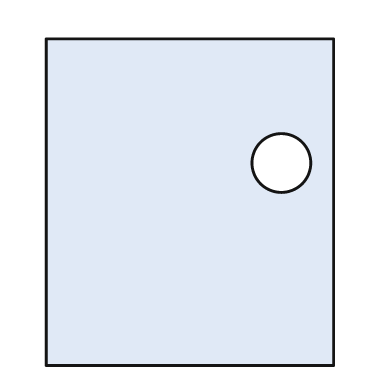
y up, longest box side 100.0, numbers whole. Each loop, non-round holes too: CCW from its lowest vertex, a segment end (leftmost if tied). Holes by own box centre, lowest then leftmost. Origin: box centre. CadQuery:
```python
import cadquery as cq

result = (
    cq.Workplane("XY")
    .moveTo(-44.0, -50.0)
    .lineTo(44.0, -50.0)
    .lineTo(44.0, 50.0)
    .lineTo(-44.0, 50.0)
    .close()
    .moveTo(28.0, 12.0)
    .circle(9.0)
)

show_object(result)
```